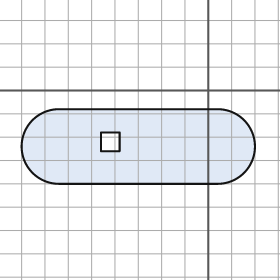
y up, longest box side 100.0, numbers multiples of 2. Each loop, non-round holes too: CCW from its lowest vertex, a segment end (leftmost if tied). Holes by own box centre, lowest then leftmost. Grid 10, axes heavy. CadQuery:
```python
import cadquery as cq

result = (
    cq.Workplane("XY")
    .moveTo(-64.0, -40.0)
    .lineTo(4.0, -40.0)
    .threePointArc((20.0, -24.0), (4.0, -8.0))
    .lineTo(-64.0, -8.0)
    .threePointArc((-80.0, -24.0), (-64.0, -40.0))
    .close()
    .moveTo(-46.0, -26.0)
    .lineTo(-38.0, -26.0)
    .lineTo(-38.0, -18.0)
    .lineTo(-46.0, -18.0)
    .close()
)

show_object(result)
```